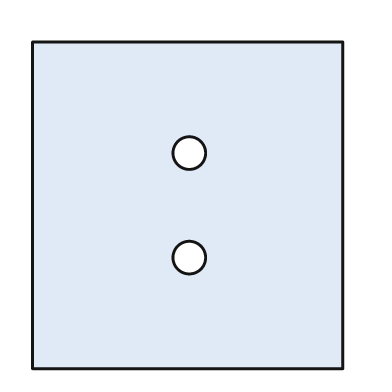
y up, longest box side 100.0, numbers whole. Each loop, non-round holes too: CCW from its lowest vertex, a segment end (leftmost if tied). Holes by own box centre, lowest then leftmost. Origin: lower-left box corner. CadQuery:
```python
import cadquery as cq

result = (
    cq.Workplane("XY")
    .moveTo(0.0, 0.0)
    .lineTo(95.0, 0.0)
    .lineTo(95.0, 100.0)
    .lineTo(0.0, 100.0)
    .close()
    .moveTo(48.0, 34.0)
    .circle(5.0)
    .moveTo(48.0, 66.0)
    .circle(5.0)
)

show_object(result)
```